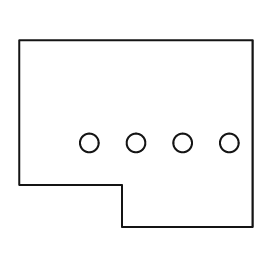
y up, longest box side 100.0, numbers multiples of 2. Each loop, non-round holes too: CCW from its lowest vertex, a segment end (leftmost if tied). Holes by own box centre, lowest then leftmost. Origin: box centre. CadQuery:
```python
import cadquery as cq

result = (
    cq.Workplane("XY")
    .moveTo(-6.0, -40.0)
    .lineTo(50.0, -40.0)
    .lineTo(50.0, 40.0)
    .lineTo(-50.0, 40.0)
    .lineTo(-50.0, -22.0)
    .lineTo(-6.0, -22.0)
    .close()
    .moveTo(-20.0, -4.0)
    .circle(4.0)
    .moveTo(0.0, -4.0)
    .circle(4.0)
    .moveTo(20.0, -4.0)
    .circle(4.0)
    .moveTo(40.0, -4.0)
    .circle(4.0)
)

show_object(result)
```